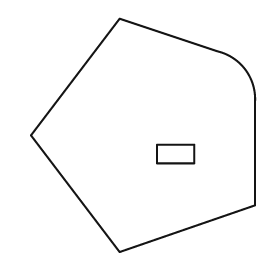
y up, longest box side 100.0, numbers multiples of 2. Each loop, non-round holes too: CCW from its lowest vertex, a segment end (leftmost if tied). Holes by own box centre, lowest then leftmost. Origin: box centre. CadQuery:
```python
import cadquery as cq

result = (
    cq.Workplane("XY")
    .moveTo(-10.0, -50.0)
    .lineTo(48.0, -30.0)
    .lineTo(48.0, 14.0)
    .threePointArc((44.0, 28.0), (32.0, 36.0))
    .lineTo(-10.0, 50.0)
    .lineTo(-48.0, 0.0)
    .close()
    .moveTo(6.0, -12.0)
    .lineTo(22.0, -12.0)
    .lineTo(22.0, -4.0)
    .lineTo(6.0, -4.0)
    .close()
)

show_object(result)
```